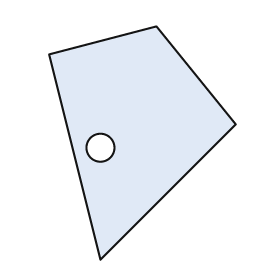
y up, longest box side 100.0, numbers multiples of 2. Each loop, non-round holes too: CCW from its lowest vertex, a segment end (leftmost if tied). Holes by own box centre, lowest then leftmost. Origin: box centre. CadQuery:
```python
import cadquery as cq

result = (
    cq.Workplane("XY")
    .moveTo(-18.0, -50.0)
    .lineTo(40.0, 8.0)
    .lineTo(6.0, 50.0)
    .lineTo(-40.0, 38.0)
    .close()
    .moveTo(-18.0, -2.0)
    .circle(6.0)
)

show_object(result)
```